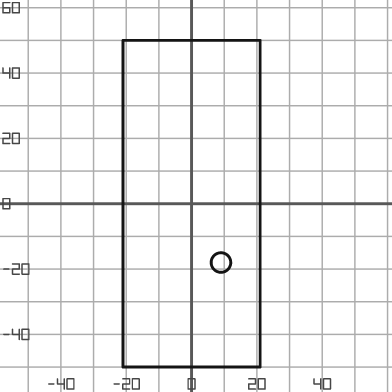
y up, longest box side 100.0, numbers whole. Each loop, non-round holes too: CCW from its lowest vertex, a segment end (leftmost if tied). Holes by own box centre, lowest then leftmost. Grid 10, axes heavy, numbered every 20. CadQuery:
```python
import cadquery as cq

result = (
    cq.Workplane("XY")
    .moveTo(-21.0, -50.0)
    .lineTo(21.0, -50.0)
    .lineTo(21.0, 50.0)
    .lineTo(-21.0, 50.0)
    .close()
    .moveTo(9.0, -18.0)
    .circle(3.0)
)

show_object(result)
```